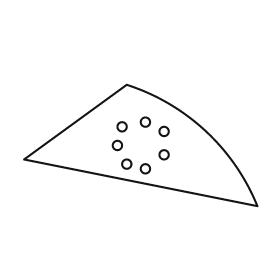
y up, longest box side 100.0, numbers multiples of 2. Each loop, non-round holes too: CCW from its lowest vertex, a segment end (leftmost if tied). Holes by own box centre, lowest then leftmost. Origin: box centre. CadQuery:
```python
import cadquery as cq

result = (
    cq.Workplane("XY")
    .moveTo(50.0, -26.0)
    .threePointArc((28.0, 6.0), (-6.0, 26.0))
    .lineTo(-50.0, -6.0)
    .close()
    .moveTo(2.0, -10.0)
    .circle(2.0)
    .moveTo(-6.0, -8.0)
    .circle(2.0)
    .moveTo(10.0, -4.0)
    .circle(2.0)
    .moveTo(-10.0, 0.0)
    .circle(2.0)
    .moveTo(10.0, 6.0)
    .circle(2.0)
    .moveTo(-8.0, 8.0)
    .circle(2.0)
    .moveTo(2.0, 10.0)
    .circle(2.0)
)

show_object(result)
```